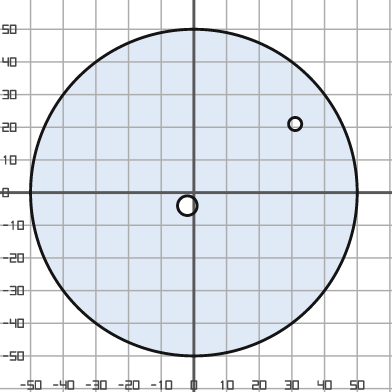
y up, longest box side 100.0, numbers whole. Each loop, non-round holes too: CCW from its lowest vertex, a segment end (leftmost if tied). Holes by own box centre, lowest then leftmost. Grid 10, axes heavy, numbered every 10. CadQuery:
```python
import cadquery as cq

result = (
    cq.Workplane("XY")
    .moveTo(0.0, 0.0)
    .circle(50.0)
    .moveTo(-2.0, -4.0)
    .circle(3.0)
    .moveTo(31.0, 21.0)
    .circle(2.0)
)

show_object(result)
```